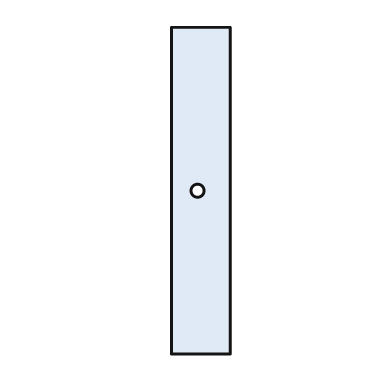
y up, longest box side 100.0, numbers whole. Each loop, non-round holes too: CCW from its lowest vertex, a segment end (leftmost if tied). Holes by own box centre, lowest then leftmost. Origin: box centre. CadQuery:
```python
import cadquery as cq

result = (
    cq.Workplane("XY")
    .moveTo(-9.0, -50.0)
    .lineTo(9.0, -50.0)
    .lineTo(9.0, 50.0)
    .lineTo(-9.0, 50.0)
    .close()
    .moveTo(-1.0, 0.0)
    .circle(2.0)
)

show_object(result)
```